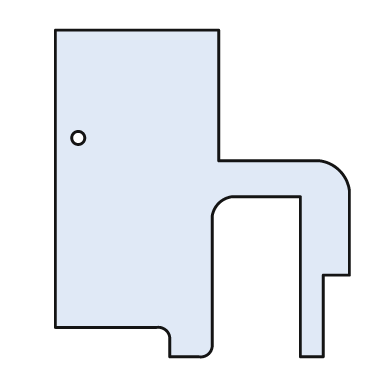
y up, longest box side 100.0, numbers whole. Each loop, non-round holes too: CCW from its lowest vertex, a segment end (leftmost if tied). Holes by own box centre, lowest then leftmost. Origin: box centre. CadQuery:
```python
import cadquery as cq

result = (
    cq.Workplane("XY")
    .moveTo(-10.0, -50.0)
    .lineTo(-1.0, -50.0)
    .threePointArc((2.0, -49.0), (3.0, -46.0))
    .lineTo(3.0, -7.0)
    .threePointArc((5.0, -3.0), (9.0, -1.0))
    .lineTo(30.0, -1.0)
    .lineTo(30.0, -50.0)
    .lineTo(37.0, -50.0)
    .lineTo(37.0, -25.0)
    .lineTo(45.0, -25.0)
    .lineTo(45.0, 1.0)
    .threePointArc((42.0, 7.0), (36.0, 10.0))
    .lineTo(5.0, 10.0)
    .lineTo(5.0, 50.0)
    .lineTo(-45.0, 50.0)
    .lineTo(-45.0, -41.0)
    .lineTo(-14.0, -41.0)
    .threePointArc((-11.0, -42.0), (-10.0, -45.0))
    .close()
    .moveTo(-38.0, 17.0)
    .circle(2.0)
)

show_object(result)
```